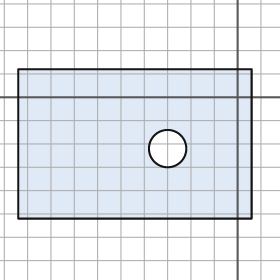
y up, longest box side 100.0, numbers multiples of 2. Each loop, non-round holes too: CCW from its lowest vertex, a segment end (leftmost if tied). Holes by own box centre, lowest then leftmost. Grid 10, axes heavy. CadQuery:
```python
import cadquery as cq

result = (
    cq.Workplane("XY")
    .moveTo(-94.0, -52.0)
    .lineTo(6.0, -52.0)
    .lineTo(6.0, 12.0)
    .lineTo(-94.0, 12.0)
    .close()
    .moveTo(-30.0, -22.0)
    .circle(8.0)
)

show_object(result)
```